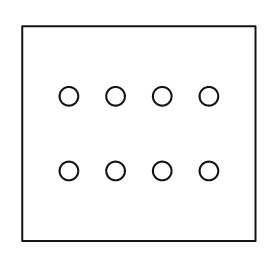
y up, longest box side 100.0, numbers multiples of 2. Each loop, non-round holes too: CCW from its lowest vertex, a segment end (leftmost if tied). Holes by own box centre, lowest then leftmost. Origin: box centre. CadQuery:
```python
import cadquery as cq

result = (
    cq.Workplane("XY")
    .moveTo(-50.0, -46.0)
    .lineTo(50.0, -46.0)
    .lineTo(50.0, 46.0)
    .lineTo(-50.0, 46.0)
    .close()
    .moveTo(-30.0, -16.0)
    .circle(4.0)
    .moveTo(-10.0, -16.0)
    .circle(4.0)
    .moveTo(10.0, -16.0)
    .circle(4.0)
    .moveTo(30.0, -16.0)
    .circle(4.0)
    .moveTo(-30.0, 16.0)
    .circle(4.0)
    .moveTo(-10.0, 16.0)
    .circle(4.0)
    .moveTo(10.0, 16.0)
    .circle(4.0)
    .moveTo(30.0, 16.0)
    .circle(4.0)
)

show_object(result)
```